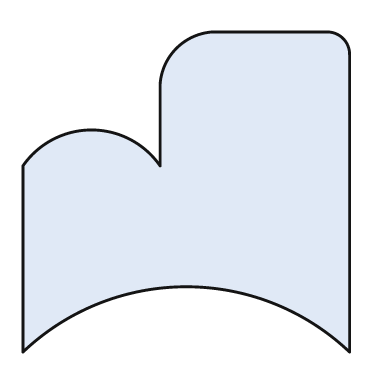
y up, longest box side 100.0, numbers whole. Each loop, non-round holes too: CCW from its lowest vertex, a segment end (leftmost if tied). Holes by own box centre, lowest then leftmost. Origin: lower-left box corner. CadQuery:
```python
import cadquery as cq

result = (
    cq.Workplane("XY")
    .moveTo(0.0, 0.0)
    .threePointArc((50.0, 20.0), (100.0, 0.0))
    .lineTo(100.0, 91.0)
    .threePointArc((98.0, 96.0), (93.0, 98.0))
    .lineTo(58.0, 98.0)
    .threePointArc((47.0, 93.0), (42.0, 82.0))
    .lineTo(42.0, 57.0)
    .threePointArc((21.0, 68.0), (0.0, 57.0))
    .close()
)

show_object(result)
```